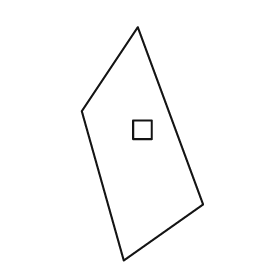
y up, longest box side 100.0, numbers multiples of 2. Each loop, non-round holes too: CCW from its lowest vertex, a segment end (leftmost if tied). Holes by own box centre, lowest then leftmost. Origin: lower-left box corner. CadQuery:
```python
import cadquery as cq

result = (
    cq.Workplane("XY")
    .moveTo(18.0, 0.0)
    .lineTo(52.0, 24.0)
    .lineTo(24.0, 100.0)
    .lineTo(0.0, 64.0)
    .close()
    .moveTo(22.0, 52.0)
    .lineTo(30.0, 52.0)
    .lineTo(30.0, 60.0)
    .lineTo(22.0, 60.0)
    .close()
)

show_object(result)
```